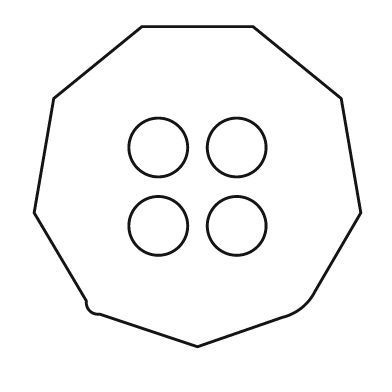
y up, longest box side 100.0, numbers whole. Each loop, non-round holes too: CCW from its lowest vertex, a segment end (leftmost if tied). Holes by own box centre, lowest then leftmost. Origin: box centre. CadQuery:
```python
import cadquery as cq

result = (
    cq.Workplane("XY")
    .moveTo(0.0, -49.0)
    .lineTo(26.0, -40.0)
    .threePointArc((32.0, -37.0), (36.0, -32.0))
    .lineTo(50.0, -8.0)
    .lineTo(44.0, 27.0)
    .lineTo(17.0, 49.0)
    .lineTo(-17.0, 49.0)
    .lineTo(-44.0, 27.0)
    .lineTo(-50.0, -8.0)
    .lineTo(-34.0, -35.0)
    .threePointArc((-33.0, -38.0), (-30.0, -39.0))
    .close()
    .moveTo(-12.0, -12.0)
    .circle(9.0)
    .moveTo(12.0, -12.0)
    .circle(9.0)
    .moveTo(-12.0, 12.0)
    .circle(9.0)
    .moveTo(12.0, 12.0)
    .circle(9.0)
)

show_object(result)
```